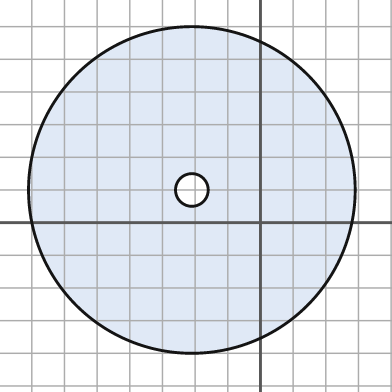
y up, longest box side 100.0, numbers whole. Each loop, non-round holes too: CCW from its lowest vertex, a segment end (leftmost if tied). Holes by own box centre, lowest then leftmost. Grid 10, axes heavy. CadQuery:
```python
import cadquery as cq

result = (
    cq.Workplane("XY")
    .moveTo(-21.0, 10.0)
    .circle(50.0)
    .moveTo(-21.0, 10.0)
    .circle(5.0)
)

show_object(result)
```